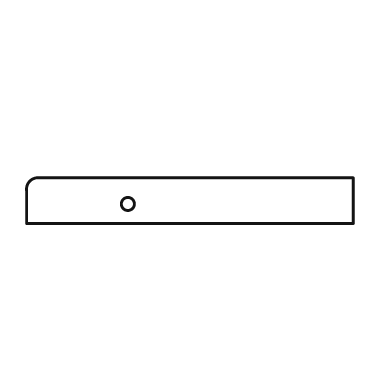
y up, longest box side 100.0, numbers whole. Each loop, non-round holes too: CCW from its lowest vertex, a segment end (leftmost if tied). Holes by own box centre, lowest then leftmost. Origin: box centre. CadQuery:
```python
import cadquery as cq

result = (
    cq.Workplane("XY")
    .moveTo(-50.0, -7.0)
    .lineTo(50.0, -7.0)
    .lineTo(50.0, 7.0)
    .lineTo(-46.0, 7.0)
    .threePointArc((-49.0, 6.0), (-50.0, 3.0))
    .close()
    .moveTo(-19.0, -1.0)
    .circle(2.0)
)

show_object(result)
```